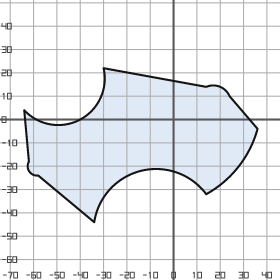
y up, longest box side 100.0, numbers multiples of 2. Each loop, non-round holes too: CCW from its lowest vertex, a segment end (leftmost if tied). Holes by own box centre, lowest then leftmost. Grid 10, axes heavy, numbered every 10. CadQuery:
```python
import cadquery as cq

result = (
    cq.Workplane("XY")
    .moveTo(-34.0, -44.0)
    .threePointArc((-14.0, -22.0), (14.0, -32.0))
    .threePointArc((28.0, -20.0), (36.0, -4.0))
    .lineTo(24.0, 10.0)
    .threePointArc((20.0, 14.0), (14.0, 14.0))
    .lineTo(-30.0, 22.0)
    .threePointArc((-40.0, 0.0), (-64.0, 4.0))
    .lineTo(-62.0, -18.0)
    .threePointArc((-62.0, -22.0), (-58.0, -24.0))
    .close()
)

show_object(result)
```